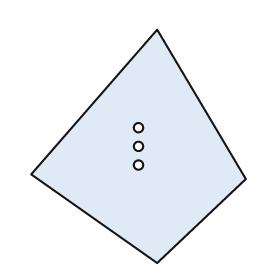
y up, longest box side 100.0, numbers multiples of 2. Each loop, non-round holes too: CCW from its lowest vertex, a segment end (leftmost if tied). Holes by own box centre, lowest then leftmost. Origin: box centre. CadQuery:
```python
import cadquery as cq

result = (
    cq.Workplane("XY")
    .moveTo(8.0, -50.0)
    .lineTo(46.0, -14.0)
    .lineTo(8.0, 50.0)
    .lineTo(-46.0, -12.0)
    .close()
    .moveTo(0.0, -8.0)
    .circle(2.0)
    .moveTo(0.0, 0.0)
    .circle(2.0)
    .moveTo(0.0, 8.0)
    .circle(2.0)
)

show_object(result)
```